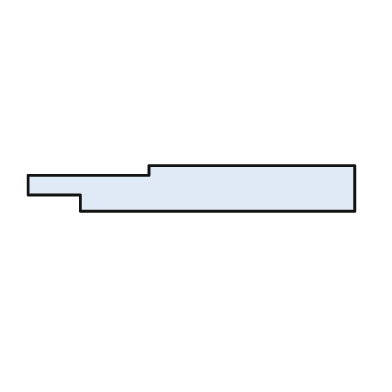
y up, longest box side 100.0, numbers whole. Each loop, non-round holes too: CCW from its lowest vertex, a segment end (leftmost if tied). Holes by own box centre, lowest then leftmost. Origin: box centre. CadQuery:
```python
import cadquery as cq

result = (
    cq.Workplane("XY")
    .moveTo(-34.0, -7.0)
    .lineTo(50.0, -7.0)
    .lineTo(50.0, 7.0)
    .lineTo(-13.0, 7.0)
    .lineTo(-13.0, 4.0)
    .lineTo(-50.0, 4.0)
    .lineTo(-50.0, -2.0)
    .lineTo(-34.0, -2.0)
    .close()
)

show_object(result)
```